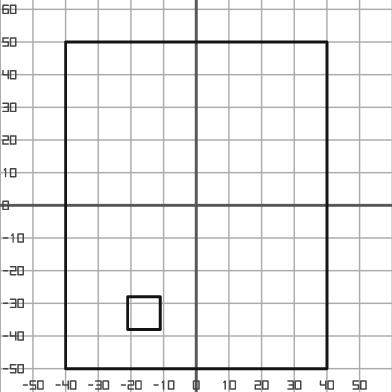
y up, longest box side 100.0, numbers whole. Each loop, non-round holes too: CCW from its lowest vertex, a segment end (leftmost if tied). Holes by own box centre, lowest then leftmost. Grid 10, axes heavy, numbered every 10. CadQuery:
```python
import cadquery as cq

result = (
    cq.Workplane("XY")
    .moveTo(-40.0, -50.0)
    .lineTo(40.0, -50.0)
    .lineTo(40.0, 50.0)
    .lineTo(-40.0, 50.0)
    .close()
    .moveTo(-21.0, -38.0)
    .lineTo(-11.0, -38.0)
    .lineTo(-11.0, -28.0)
    .lineTo(-21.0, -28.0)
    .close()
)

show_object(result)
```